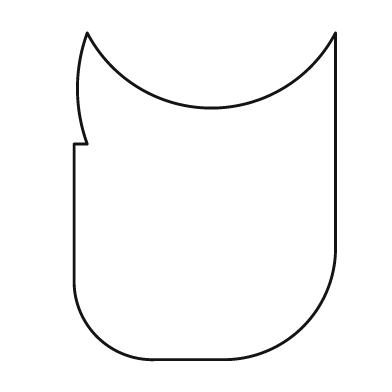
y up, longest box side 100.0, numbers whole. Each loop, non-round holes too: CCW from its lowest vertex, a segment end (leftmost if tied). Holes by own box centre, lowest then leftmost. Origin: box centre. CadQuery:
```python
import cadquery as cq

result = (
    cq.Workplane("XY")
    .moveTo(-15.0, -50.0)
    .lineTo(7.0, -50.0)
    .threePointArc((30.0, -40.0), (40.0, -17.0))
    .lineTo(40.0, 50.0)
    .threePointArc((2.0, 27.0), (-36.0, 50.0))
    .threePointArc((-39.0, 33.0), (-36.0, 16.0))
    .lineTo(-40.0, 16.0)
    .lineTo(-40.0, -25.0)
    .threePointArc((-33.0, -43.0), (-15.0, -50.0))
    .close()
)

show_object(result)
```